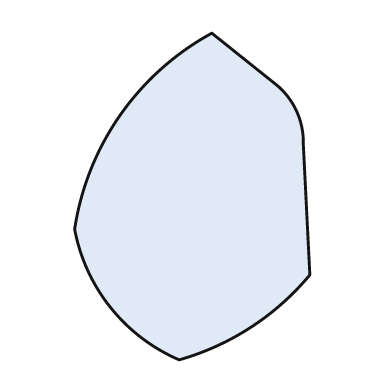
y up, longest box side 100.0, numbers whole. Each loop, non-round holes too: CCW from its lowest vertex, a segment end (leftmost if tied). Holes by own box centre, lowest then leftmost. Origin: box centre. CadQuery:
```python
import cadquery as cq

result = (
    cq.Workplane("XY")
    .moveTo(-4.0, -50.0)
    .threePointArc((18.0, -40.0), (36.0, -24.0))
    .lineTo(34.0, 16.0)
    .threePointArc((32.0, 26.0), (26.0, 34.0))
    .lineTo(6.0, 50.0)
    .threePointArc((-22.0, 25.0), (-36.0, -10.0))
    .threePointArc((-25.0, -34.0), (-4.0, -50.0))
    .close()
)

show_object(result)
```